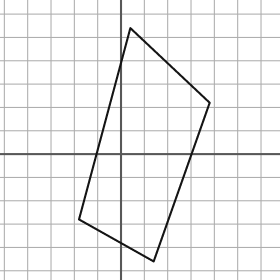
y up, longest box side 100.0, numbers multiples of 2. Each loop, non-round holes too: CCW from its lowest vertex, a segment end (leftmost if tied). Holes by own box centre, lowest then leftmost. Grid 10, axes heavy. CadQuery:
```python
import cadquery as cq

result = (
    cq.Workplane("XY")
    .moveTo(14.0, -46.0)
    .lineTo(38.0, 22.0)
    .lineTo(4.0, 54.0)
    .lineTo(-18.0, -28.0)
    .close()
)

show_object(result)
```